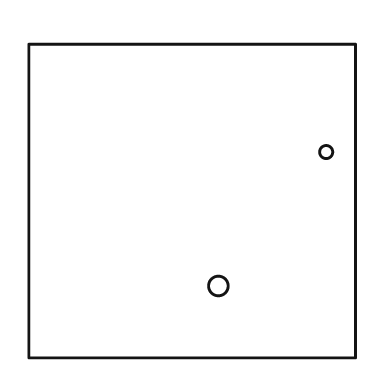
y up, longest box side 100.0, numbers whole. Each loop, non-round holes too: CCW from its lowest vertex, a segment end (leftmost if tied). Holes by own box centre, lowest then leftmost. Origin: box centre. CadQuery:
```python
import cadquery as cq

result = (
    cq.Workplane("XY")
    .moveTo(-50.0, -48.0)
    .lineTo(50.0, -48.0)
    .lineTo(50.0, 48.0)
    .lineTo(-50.0, 48.0)
    .close()
    .moveTo(8.0, -26.0)
    .circle(3.0)
    .moveTo(41.0, 15.0)
    .circle(2.0)
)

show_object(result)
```